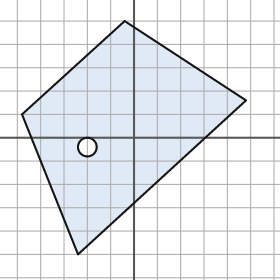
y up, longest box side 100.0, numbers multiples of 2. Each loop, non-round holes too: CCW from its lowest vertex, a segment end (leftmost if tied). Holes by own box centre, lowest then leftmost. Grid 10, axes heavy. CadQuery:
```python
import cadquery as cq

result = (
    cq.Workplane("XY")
    .moveTo(-24.0, -50.0)
    .lineTo(48.0, 16.0)
    .lineTo(-4.0, 50.0)
    .lineTo(-48.0, 10.0)
    .close()
    .moveTo(-20.0, -4.0)
    .circle(4.0)
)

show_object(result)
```